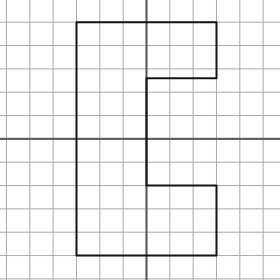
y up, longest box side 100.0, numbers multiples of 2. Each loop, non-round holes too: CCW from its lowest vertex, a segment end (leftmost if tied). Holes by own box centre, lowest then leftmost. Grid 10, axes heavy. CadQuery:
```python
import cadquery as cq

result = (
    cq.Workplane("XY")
    .moveTo(-30.0, -50.0)
    .lineTo(30.0, -50.0)
    .lineTo(30.0, -20.0)
    .lineTo(0.0, -20.0)
    .lineTo(0.0, 26.0)
    .lineTo(30.0, 26.0)
    .lineTo(30.0, 50.0)
    .lineTo(-30.0, 50.0)
    .close()
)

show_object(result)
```